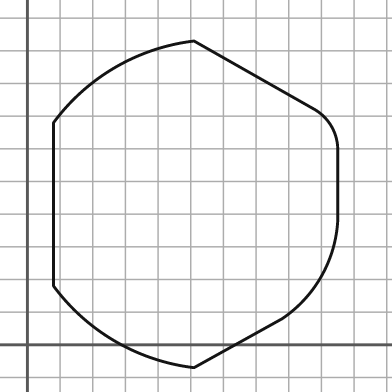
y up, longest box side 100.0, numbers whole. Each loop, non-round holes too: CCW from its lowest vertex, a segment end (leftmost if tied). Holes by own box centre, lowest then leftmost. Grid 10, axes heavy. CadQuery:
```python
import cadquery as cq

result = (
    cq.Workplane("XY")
    .moveTo(51.0, -7.0)
    .lineTo(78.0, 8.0)
    .threePointArc((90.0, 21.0), (95.0, 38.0))
    .lineTo(95.0, 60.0)
    .threePointArc((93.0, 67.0), (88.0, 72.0))
    .lineTo(51.0, 93.0)
    .threePointArc((27.0, 85.0), (8.0, 68.0))
    .lineTo(8.0, 18.0)
    .threePointArc((27.0, 1.0), (51.0, -7.0))
    .close()
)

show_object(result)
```